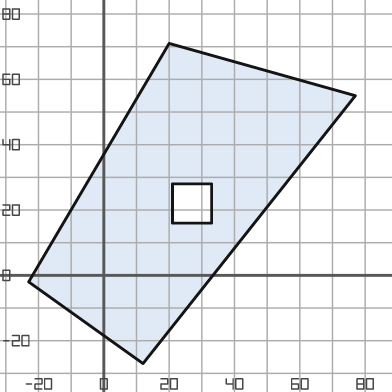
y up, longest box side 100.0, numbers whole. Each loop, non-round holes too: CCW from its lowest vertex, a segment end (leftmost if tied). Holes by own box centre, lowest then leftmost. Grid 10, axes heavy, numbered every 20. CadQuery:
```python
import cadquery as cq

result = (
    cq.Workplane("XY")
    .moveTo(12.0, -27.0)
    .lineTo(77.0, 55.0)
    .lineTo(20.0, 71.0)
    .lineTo(-23.0, -2.0)
    .close()
    .moveTo(21.0, 16.0)
    .lineTo(33.0, 16.0)
    .lineTo(33.0, 28.0)
    .lineTo(21.0, 28.0)
    .close()
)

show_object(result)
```